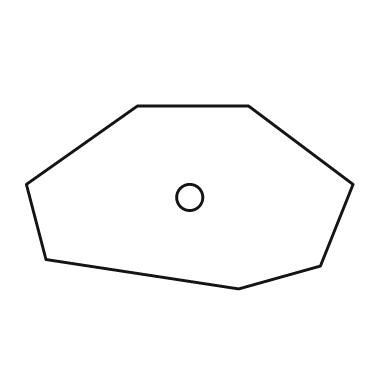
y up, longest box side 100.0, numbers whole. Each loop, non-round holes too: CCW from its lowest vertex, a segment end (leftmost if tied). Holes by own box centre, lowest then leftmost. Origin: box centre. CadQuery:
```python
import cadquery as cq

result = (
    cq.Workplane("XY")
    .moveTo(15.0, -28.0)
    .lineTo(40.0, -21.0)
    .lineTo(50.0, 4.0)
    .lineTo(18.0, 28.0)
    .lineTo(-16.0, 28.0)
    .lineTo(-50.0, 4.0)
    .lineTo(-44.0, -19.0)
    .close()
    .moveTo(0.0, 0.0)
    .circle(4.0)
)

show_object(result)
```